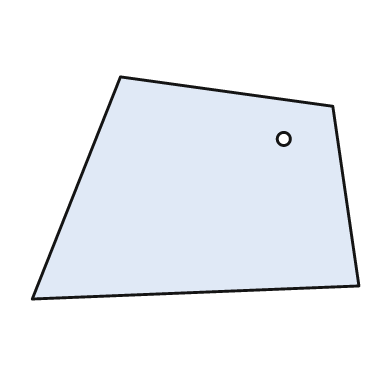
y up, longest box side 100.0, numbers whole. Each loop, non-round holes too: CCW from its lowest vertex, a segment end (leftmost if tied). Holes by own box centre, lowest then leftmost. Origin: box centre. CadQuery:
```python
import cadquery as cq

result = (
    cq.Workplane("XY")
    .moveTo(-50.0, -34.0)
    .lineTo(50.0, -30.0)
    .lineTo(42.0, 25.0)
    .lineTo(-23.0, 34.0)
    .close()
    .moveTo(27.0, 15.0)
    .circle(2.0)
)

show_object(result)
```